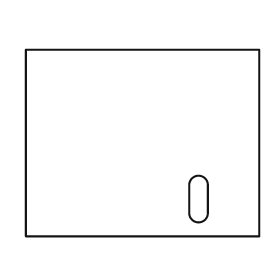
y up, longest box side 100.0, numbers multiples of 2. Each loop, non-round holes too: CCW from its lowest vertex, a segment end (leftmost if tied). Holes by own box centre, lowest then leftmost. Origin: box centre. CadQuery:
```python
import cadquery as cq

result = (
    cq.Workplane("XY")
    .moveTo(-50.0, -40.0)
    .lineTo(50.0, -40.0)
    .lineTo(50.0, 40.0)
    .lineTo(-50.0, 40.0)
    .close()
    .moveTo(20.0, -30.0)
    .threePointArc((24.0, -34.0), (28.0, -30.0))
    .lineTo(28.0, -18.0)
    .threePointArc((24.0, -14.0), (20.0, -18.0))
    .close()
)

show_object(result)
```